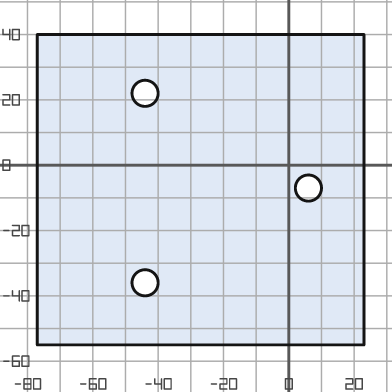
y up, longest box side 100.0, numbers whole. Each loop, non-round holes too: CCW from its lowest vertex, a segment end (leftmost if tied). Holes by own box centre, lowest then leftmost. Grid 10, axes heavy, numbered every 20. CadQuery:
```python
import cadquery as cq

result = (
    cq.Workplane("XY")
    .moveTo(-77.0, -55.0)
    .lineTo(23.0, -55.0)
    .lineTo(23.0, 40.0)
    .lineTo(-77.0, 40.0)
    .close()
    .moveTo(-44.0, -36.0)
    .circle(4.0)
    .moveTo(6.0, -7.0)
    .circle(4.0)
    .moveTo(-44.0, 22.0)
    .circle(4.0)
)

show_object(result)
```